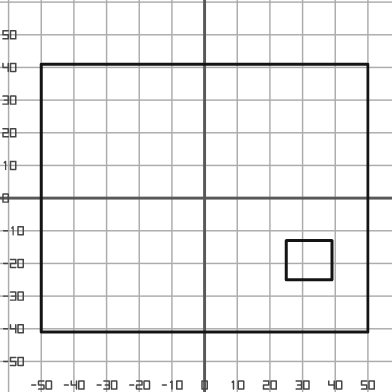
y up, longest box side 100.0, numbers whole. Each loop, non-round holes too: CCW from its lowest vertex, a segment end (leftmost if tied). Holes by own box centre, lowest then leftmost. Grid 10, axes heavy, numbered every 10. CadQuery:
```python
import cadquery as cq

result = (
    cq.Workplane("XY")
    .moveTo(-50.0, -41.0)
    .lineTo(50.0, -41.0)
    .lineTo(50.0, 41.0)
    .lineTo(-50.0, 41.0)
    .close()
    .moveTo(25.0, -25.0)
    .lineTo(39.0, -25.0)
    .lineTo(39.0, -13.0)
    .lineTo(25.0, -13.0)
    .close()
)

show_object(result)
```